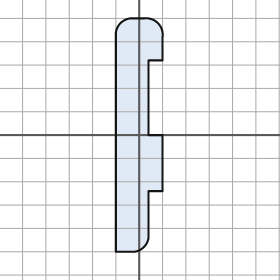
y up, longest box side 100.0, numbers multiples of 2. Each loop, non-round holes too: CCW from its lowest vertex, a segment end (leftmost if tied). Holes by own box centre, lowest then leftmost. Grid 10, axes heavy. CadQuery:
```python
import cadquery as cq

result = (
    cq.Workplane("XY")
    .moveTo(-10.0, -50.0)
    .lineTo(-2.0, -50.0)
    .threePointArc((2.0, -48.0), (4.0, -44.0))
    .lineTo(4.0, -24.0)
    .lineTo(10.0, -24.0)
    .lineTo(10.0, 0.0)
    .lineTo(4.0, 0.0)
    .lineTo(4.0, 32.0)
    .lineTo(10.0, 32.0)
    .lineTo(10.0, 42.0)
    .threePointArc((8.0, 48.0), (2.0, 50.0))
    .lineTo(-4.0, 50.0)
    .threePointArc((-8.0, 48.0), (-10.0, 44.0))
    .close()
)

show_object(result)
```